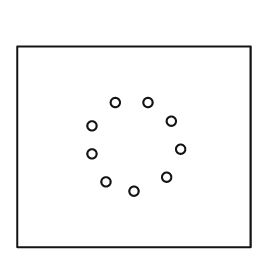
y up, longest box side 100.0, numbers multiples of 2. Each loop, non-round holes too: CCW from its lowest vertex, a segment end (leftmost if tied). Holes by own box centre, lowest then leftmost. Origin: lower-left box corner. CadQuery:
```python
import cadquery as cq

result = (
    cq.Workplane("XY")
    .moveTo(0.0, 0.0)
    .lineTo(100.0, 0.0)
    .lineTo(100.0, 86.0)
    .lineTo(0.0, 86.0)
    .close()
    .moveTo(50.0, 24.0)
    .circle(2.0)
    .moveTo(38.0, 28.0)
    .circle(2.0)
    .moveTo(64.0, 30.0)
    .circle(2.0)
    .moveTo(32.0, 40.0)
    .circle(2.0)
    .moveTo(70.0, 42.0)
    .circle(2.0)
    .moveTo(32.0, 52.0)
    .circle(2.0)
    .moveTo(66.0, 54.0)
    .circle(2.0)
    .moveTo(42.0, 62.0)
    .circle(2.0)
    .moveTo(56.0, 62.0)
    .circle(2.0)
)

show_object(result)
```